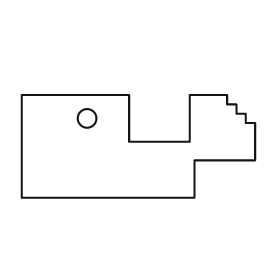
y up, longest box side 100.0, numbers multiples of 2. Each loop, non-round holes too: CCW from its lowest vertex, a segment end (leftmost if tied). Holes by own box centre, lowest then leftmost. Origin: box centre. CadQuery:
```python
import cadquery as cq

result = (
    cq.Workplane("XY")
    .moveTo(-50.0, -22.0)
    .lineTo(24.0, -22.0)
    .lineTo(24.0, -6.0)
    .lineTo(50.0, -6.0)
    .lineTo(50.0, 10.0)
    .lineTo(46.0, 10.0)
    .lineTo(46.0, 14.0)
    .lineTo(42.0, 14.0)
    .lineTo(42.0, 18.0)
    .lineTo(38.0, 18.0)
    .lineTo(38.0, 22.0)
    .lineTo(22.0, 22.0)
    .lineTo(22.0, 2.0)
    .lineTo(-4.0, 2.0)
    .lineTo(-4.0, 22.0)
    .lineTo(-50.0, 22.0)
    .close()
    .moveTo(-22.0, 12.0)
    .circle(4.0)
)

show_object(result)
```